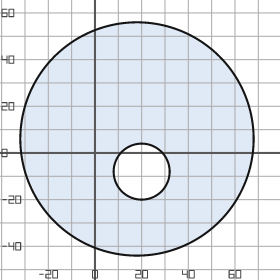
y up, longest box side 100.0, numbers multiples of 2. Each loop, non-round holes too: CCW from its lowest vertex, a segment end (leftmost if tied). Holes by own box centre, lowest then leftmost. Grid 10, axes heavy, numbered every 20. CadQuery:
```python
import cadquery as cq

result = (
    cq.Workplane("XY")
    .moveTo(18.0, 6.0)
    .circle(50.0)
    .moveTo(20.0, -8.0)
    .circle(12.0)
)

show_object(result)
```